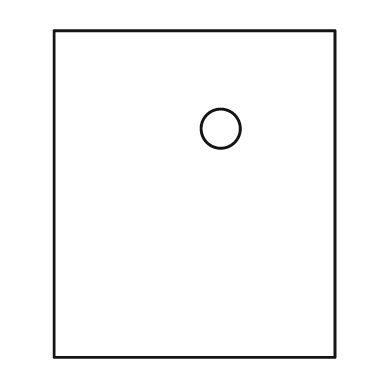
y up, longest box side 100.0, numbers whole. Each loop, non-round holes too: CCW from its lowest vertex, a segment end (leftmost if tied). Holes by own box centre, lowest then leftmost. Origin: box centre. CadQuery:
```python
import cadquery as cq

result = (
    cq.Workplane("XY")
    .moveTo(-43.0, -50.0)
    .lineTo(43.0, -50.0)
    .lineTo(43.0, 50.0)
    .lineTo(-43.0, 50.0)
    .close()
    .moveTo(8.0, 20.0)
    .circle(6.0)
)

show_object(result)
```